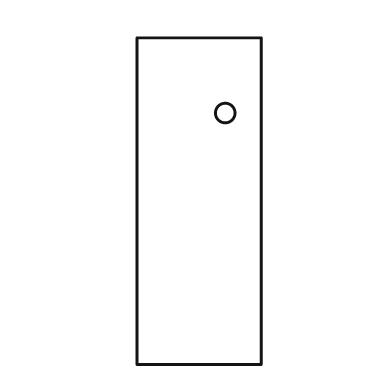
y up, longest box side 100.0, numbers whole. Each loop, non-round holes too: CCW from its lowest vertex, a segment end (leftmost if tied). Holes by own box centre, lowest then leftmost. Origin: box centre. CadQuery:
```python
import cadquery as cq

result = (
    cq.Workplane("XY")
    .moveTo(-19.0, -50.0)
    .lineTo(19.0, -50.0)
    .lineTo(19.0, 50.0)
    .lineTo(-19.0, 50.0)
    .close()
    .moveTo(8.0, 27.0)
    .circle(3.0)
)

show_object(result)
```